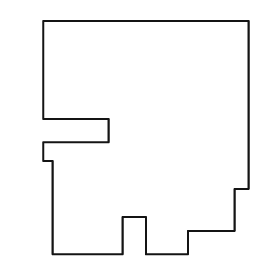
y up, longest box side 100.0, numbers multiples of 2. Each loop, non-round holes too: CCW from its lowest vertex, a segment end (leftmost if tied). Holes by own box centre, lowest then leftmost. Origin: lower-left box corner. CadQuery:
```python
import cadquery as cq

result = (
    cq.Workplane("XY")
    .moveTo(4.0, 0.0)
    .lineTo(34.0, 0.0)
    .lineTo(34.0, 16.0)
    .lineTo(44.0, 16.0)
    .lineTo(44.0, 0.0)
    .lineTo(62.0, 0.0)
    .lineTo(62.0, 10.0)
    .lineTo(82.0, 10.0)
    .lineTo(82.0, 28.0)
    .lineTo(88.0, 28.0)
    .lineTo(88.0, 100.0)
    .lineTo(0.0, 100.0)
    .lineTo(0.0, 58.0)
    .lineTo(28.0, 58.0)
    .lineTo(28.0, 48.0)
    .lineTo(0.0, 48.0)
    .lineTo(0.0, 40.0)
    .lineTo(4.0, 40.0)
    .close()
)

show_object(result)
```